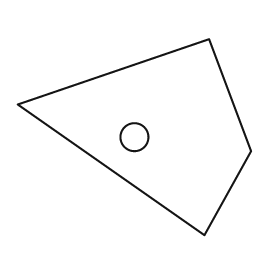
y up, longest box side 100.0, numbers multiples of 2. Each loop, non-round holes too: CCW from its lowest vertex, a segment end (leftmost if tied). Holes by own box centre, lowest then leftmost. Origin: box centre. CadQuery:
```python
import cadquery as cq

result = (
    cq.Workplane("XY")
    .moveTo(30.0, -42.0)
    .lineTo(50.0, -6.0)
    .lineTo(32.0, 42.0)
    .lineTo(-50.0, 14.0)
    .close()
    .moveTo(0.0, 0.0)
    .circle(6.0)
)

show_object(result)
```